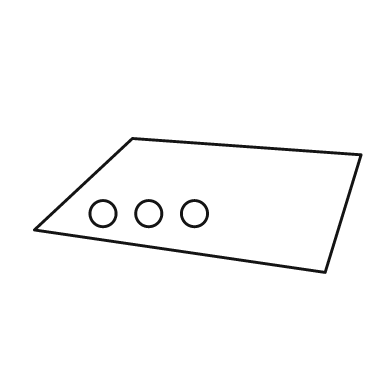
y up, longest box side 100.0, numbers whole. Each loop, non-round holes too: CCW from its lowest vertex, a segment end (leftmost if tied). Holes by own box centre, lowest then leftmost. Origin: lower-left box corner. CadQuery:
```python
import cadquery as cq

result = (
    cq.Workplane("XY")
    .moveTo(89.0, 0.0)
    .lineTo(100.0, 36.0)
    .lineTo(30.0, 41.0)
    .lineTo(0.0, 13.0)
    .close()
    .moveTo(21.0, 18.0)
    .circle(4.0)
    .moveTo(35.0, 18.0)
    .circle(4.0)
    .moveTo(49.0, 18.0)
    .circle(4.0)
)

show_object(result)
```